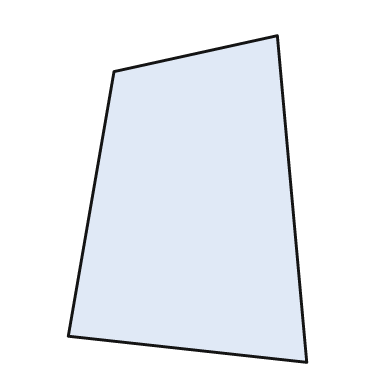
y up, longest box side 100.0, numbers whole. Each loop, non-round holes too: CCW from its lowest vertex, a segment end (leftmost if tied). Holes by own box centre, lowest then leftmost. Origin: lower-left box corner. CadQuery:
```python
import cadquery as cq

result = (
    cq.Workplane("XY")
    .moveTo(73.0, 0.0)
    .lineTo(64.0, 100.0)
    .lineTo(14.0, 89.0)
    .lineTo(0.0, 8.0)
    .close()
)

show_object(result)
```